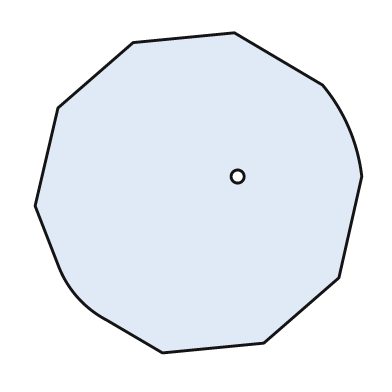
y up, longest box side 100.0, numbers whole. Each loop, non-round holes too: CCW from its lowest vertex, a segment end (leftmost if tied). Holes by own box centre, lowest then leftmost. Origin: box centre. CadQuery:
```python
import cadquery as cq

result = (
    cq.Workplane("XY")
    .moveTo(-11.0, -49.0)
    .lineTo(20.0, -46.0)
    .lineTo(43.0, -26.0)
    .lineTo(50.0, 5.0)
    .threePointArc((46.0, 20.0), (38.0, 33.0))
    .lineTo(11.0, 49.0)
    .lineTo(-20.0, 46.0)
    .lineTo(-43.0, 26.0)
    .lineTo(-50.0, -4.0)
    .lineTo(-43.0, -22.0)
    .threePointArc((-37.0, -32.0), (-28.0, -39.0))
    .close()
    .moveTo(12.0, 5.0)
    .circle(2.0)
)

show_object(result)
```